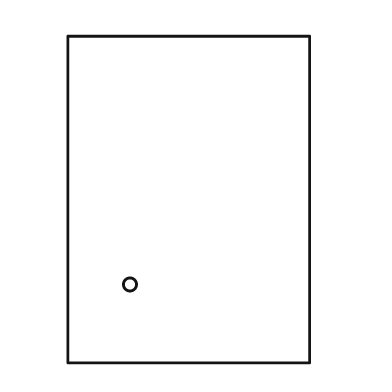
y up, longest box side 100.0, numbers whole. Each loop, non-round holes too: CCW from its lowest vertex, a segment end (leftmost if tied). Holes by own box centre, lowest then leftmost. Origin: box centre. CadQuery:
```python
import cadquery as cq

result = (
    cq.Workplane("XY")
    .moveTo(-37.0, -50.0)
    .lineTo(37.0, -50.0)
    .lineTo(37.0, 50.0)
    .lineTo(-37.0, 50.0)
    .close()
    .moveTo(-18.0, -26.0)
    .circle(2.0)
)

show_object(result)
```